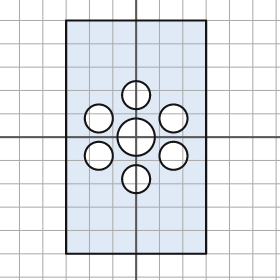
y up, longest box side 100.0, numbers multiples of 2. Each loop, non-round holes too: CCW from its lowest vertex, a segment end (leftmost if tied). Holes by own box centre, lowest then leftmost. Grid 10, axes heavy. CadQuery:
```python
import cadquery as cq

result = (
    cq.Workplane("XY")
    .moveTo(-30.0, -50.0)
    .lineTo(30.0, -50.0)
    .lineTo(30.0, 50.0)
    .lineTo(-30.0, 50.0)
    .close()
    .moveTo(0.0, -18.0)
    .circle(6.0)
    .moveTo(-16.0, -8.0)
    .circle(6.0)
    .moveTo(16.0, -8.0)
    .circle(6.0)
    .moveTo(0.0, 0.0)
    .circle(8.0)
    .moveTo(-16.0, 8.0)
    .circle(6.0)
    .moveTo(16.0, 8.0)
    .circle(6.0)
    .moveTo(0.0, 18.0)
    .circle(6.0)
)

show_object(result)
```